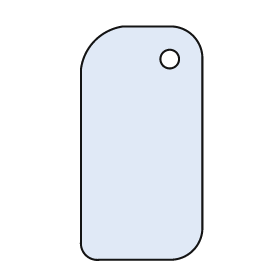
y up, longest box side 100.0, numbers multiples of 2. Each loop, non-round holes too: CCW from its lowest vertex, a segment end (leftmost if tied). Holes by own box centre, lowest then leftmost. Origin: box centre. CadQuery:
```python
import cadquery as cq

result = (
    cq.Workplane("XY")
    .moveTo(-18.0, -50.0)
    .lineTo(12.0, -50.0)
    .threePointArc((22.0, -46.0), (26.0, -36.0))
    .lineTo(26.0, 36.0)
    .threePointArc((22.0, 46.0), (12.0, 50.0))
    .lineTo(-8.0, 50.0)
    .threePointArc((-20.0, 44.0), (-26.0, 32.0))
    .lineTo(-26.0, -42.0)
    .threePointArc((-24.0, -48.0), (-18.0, -50.0))
    .close()
    .moveTo(12.0, 36.0)
    .circle(4.0)
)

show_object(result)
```